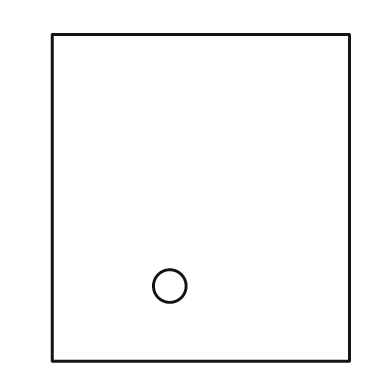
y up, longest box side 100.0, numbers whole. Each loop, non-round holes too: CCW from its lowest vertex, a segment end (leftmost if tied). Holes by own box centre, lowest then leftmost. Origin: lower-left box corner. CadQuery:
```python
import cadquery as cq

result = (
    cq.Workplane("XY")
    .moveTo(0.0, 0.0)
    .lineTo(91.0, 0.0)
    .lineTo(91.0, 100.0)
    .lineTo(0.0, 100.0)
    .close()
    .moveTo(36.0, 23.0)
    .circle(5.0)
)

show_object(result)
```